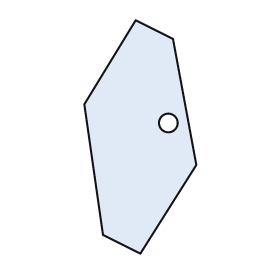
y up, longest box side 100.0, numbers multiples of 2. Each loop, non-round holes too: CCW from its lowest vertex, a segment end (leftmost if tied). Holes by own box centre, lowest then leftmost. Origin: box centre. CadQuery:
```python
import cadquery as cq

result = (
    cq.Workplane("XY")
    .moveTo(0.0, -50.0)
    .lineTo(24.0, -12.0)
    .lineTo(14.0, 42.0)
    .lineTo(-2.0, 50.0)
    .lineTo(-24.0, 14.0)
    .lineTo(-16.0, -42.0)
    .close()
    .moveTo(12.0, 6.0)
    .circle(4.0)
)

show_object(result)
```